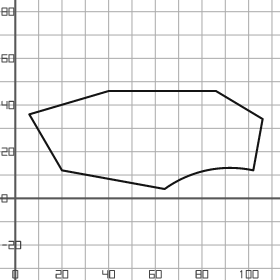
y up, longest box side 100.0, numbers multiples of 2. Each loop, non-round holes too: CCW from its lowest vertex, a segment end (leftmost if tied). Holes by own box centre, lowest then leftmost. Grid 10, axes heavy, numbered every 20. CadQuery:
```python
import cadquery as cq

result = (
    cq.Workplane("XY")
    .moveTo(64.0, 4.0)
    .threePointArc((82.0, 12.0), (102.0, 12.0))
    .lineTo(106.0, 34.0)
    .lineTo(86.0, 46.0)
    .lineTo(40.0, 46.0)
    .lineTo(6.0, 36.0)
    .lineTo(20.0, 12.0)
    .close()
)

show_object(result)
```